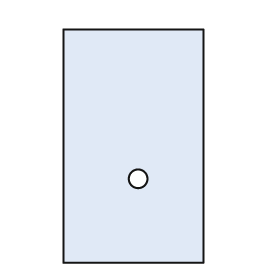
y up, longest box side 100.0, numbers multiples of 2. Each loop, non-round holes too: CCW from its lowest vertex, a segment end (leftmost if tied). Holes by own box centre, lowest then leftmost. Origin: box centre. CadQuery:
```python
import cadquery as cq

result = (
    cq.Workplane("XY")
    .moveTo(-30.0, -50.0)
    .lineTo(30.0, -50.0)
    .lineTo(30.0, 50.0)
    .lineTo(-30.0, 50.0)
    .close()
    .moveTo(2.0, -14.0)
    .circle(4.0)
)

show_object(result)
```